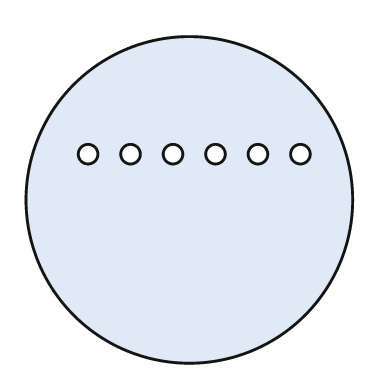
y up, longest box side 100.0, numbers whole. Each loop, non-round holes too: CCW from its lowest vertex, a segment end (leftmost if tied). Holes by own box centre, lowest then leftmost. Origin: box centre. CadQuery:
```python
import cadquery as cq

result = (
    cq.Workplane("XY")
    .moveTo(0.0, 0.0)
    .circle(50.0)
    .moveTo(-31.0, 14.0)
    .circle(3.0)
    .moveTo(-18.0, 14.0)
    .circle(3.0)
    .moveTo(-5.0, 14.0)
    .circle(3.0)
    .moveTo(8.0, 14.0)
    .circle(3.0)
    .moveTo(21.0, 14.0)
    .circle(3.0)
    .moveTo(34.0, 14.0)
    .circle(3.0)
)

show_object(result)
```